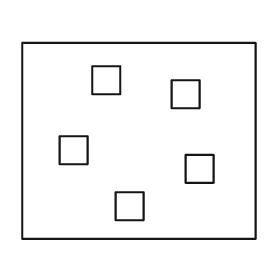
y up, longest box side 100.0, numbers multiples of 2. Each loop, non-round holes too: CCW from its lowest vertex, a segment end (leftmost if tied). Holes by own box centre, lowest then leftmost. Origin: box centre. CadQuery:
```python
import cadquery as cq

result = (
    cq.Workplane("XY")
    .moveTo(-50.0, -42.0)
    .lineTo(50.0, -42.0)
    .lineTo(50.0, 42.0)
    .lineTo(-50.0, 42.0)
    .close()
    .moveTo(-10.0, -34.0)
    .lineTo(2.0, -34.0)
    .lineTo(2.0, -22.0)
    .lineTo(-10.0, -22.0)
    .close()
    .moveTo(20.0, -18.0)
    .lineTo(32.0, -18.0)
    .lineTo(32.0, -6.0)
    .lineTo(20.0, -6.0)
    .close()
    .moveTo(-34.0, -10.0)
    .lineTo(-22.0, -10.0)
    .lineTo(-22.0, 2.0)
    .lineTo(-34.0, 2.0)
    .close()
    .moveTo(14.0, 14.0)
    .lineTo(26.0, 14.0)
    .lineTo(26.0, 26.0)
    .lineTo(14.0, 26.0)
    .close()
    .moveTo(-20.0, 20.0)
    .lineTo(-8.0, 20.0)
    .lineTo(-8.0, 32.0)
    .lineTo(-20.0, 32.0)
    .close()
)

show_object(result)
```